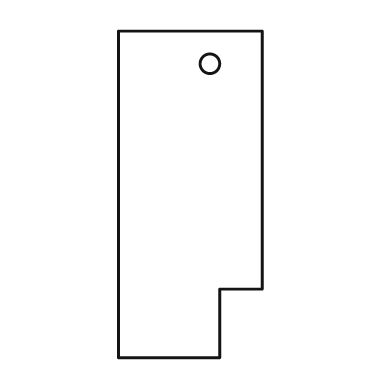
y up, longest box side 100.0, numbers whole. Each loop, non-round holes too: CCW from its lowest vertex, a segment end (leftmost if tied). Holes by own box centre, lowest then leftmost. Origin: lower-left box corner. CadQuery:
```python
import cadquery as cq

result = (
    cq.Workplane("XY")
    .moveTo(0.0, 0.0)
    .lineTo(31.0, 0.0)
    .lineTo(31.0, 21.0)
    .lineTo(44.0, 21.0)
    .lineTo(44.0, 100.0)
    .lineTo(0.0, 100.0)
    .close()
    .moveTo(28.0, 90.0)
    .circle(3.0)
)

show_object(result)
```